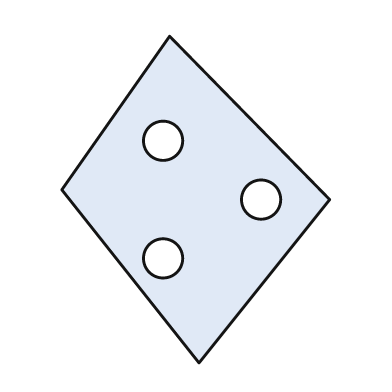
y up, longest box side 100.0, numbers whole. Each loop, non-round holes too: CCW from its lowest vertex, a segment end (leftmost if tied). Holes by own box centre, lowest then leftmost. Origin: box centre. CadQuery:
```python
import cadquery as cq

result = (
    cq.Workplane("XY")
    .moveTo(1.0, -50.0)
    .lineTo(41.0, 0.0)
    .lineTo(-8.0, 50.0)
    .lineTo(-41.0, 3.0)
    .close()
    .moveTo(-10.0, -18.0)
    .circle(6.0)
    .moveTo(20.0, 0.0)
    .circle(6.0)
    .moveTo(-10.0, 18.0)
    .circle(6.0)
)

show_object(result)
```